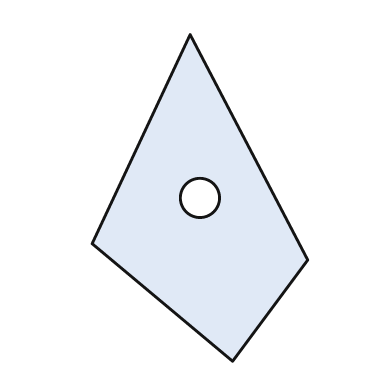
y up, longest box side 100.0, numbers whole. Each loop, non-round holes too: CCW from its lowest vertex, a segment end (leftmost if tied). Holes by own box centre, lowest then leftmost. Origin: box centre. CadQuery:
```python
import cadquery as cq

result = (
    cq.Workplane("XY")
    .moveTo(10.0, -50.0)
    .lineTo(33.0, -19.0)
    .lineTo(-3.0, 50.0)
    .lineTo(-33.0, -14.0)
    .close()
    .moveTo(0.0, 0.0)
    .circle(6.0)
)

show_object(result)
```